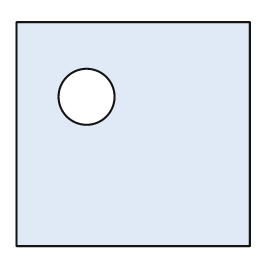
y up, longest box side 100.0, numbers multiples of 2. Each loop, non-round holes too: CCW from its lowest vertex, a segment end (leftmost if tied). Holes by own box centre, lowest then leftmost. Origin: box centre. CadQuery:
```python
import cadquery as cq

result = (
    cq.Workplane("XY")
    .moveTo(-50.0, -48.0)
    .lineTo(50.0, -48.0)
    .lineTo(50.0, 48.0)
    .lineTo(-50.0, 48.0)
    .close()
    .moveTo(-20.0, 16.0)
    .circle(12.0)
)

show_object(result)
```